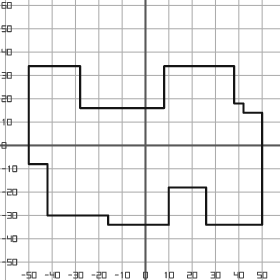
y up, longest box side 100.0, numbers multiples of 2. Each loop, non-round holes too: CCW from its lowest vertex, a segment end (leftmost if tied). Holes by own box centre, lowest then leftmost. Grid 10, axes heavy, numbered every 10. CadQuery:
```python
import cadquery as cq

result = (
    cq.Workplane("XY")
    .moveTo(-16.0, -34.0)
    .lineTo(10.0, -34.0)
    .lineTo(10.0, -18.0)
    .lineTo(26.0, -18.0)
    .lineTo(26.0, -34.0)
    .lineTo(50.0, -34.0)
    .lineTo(50.0, 14.0)
    .lineTo(42.0, 14.0)
    .lineTo(42.0, 18.0)
    .lineTo(38.0, 18.0)
    .lineTo(38.0, 34.0)
    .lineTo(8.0, 34.0)
    .lineTo(8.0, 16.0)
    .lineTo(-28.0, 16.0)
    .lineTo(-28.0, 34.0)
    .lineTo(-50.0, 34.0)
    .lineTo(-50.0, -8.0)
    .lineTo(-42.0, -8.0)
    .lineTo(-42.0, -30.0)
    .lineTo(-16.0, -30.0)
    .close()
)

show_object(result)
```